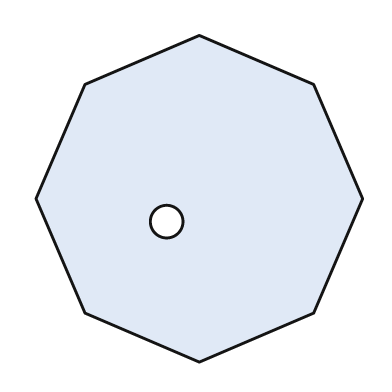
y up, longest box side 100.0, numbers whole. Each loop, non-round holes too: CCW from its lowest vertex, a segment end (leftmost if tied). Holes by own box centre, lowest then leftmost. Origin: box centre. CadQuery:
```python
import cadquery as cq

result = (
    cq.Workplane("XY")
    .moveTo(0.0, -50.0)
    .lineTo(35.0, -35.0)
    .lineTo(50.0, 0.0)
    .lineTo(35.0, 35.0)
    .lineTo(0.0, 50.0)
    .lineTo(-35.0, 35.0)
    .lineTo(-50.0, 0.0)
    .lineTo(-35.0, -35.0)
    .close()
    .moveTo(-10.0, -7.0)
    .circle(5.0)
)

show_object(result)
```